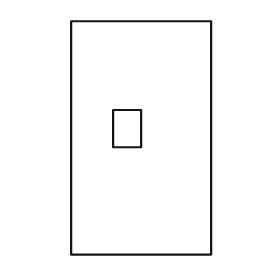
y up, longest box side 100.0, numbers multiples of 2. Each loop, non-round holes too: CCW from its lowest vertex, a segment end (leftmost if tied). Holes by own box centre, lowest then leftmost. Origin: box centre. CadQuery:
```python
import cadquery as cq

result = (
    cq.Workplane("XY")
    .moveTo(-30.0, -50.0)
    .lineTo(30.0, -50.0)
    .lineTo(30.0, 50.0)
    .lineTo(-30.0, 50.0)
    .close()
    .moveTo(-12.0, -4.0)
    .lineTo(0.0, -4.0)
    .lineTo(0.0, 12.0)
    .lineTo(-12.0, 12.0)
    .close()
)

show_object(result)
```